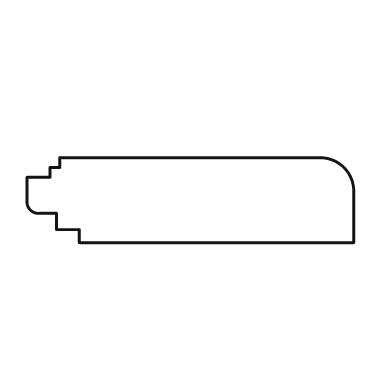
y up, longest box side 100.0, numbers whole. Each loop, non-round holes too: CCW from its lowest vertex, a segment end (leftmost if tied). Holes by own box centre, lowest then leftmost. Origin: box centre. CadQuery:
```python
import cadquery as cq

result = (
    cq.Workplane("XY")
    .moveTo(-34.0, -13.0)
    .lineTo(50.0, -13.0)
    .lineTo(50.0, 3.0)
    .threePointArc((47.0, 10.0), (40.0, 13.0))
    .lineTo(-40.0, 13.0)
    .lineTo(-40.0, 10.0)
    .lineTo(-43.0, 10.0)
    .lineTo(-43.0, 7.0)
    .lineTo(-50.0, 7.0)
    .lineTo(-50.0, 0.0)
    .threePointArc((-49.0, -3.0), (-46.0, -4.0))
    .lineTo(-41.0, -4.0)
    .lineTo(-41.0, -9.0)
    .lineTo(-34.0, -9.0)
    .close()
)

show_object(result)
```